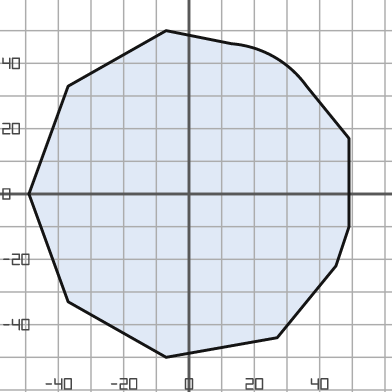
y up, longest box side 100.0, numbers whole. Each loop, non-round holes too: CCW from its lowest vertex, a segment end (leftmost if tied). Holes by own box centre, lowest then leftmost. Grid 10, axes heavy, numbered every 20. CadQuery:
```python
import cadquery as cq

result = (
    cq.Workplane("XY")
    .moveTo(-7.0, -50.0)
    .lineTo(27.0, -44.0)
    .lineTo(45.0, -22.0)
    .lineTo(49.0, -10.0)
    .lineTo(49.0, 17.0)
    .lineTo(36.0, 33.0)
    .threePointArc((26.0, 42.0), (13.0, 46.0))
    .lineTo(-7.0, 50.0)
    .lineTo(-37.0, 33.0)
    .lineTo(-49.0, 0.0)
    .lineTo(-37.0, -33.0)
    .close()
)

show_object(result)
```